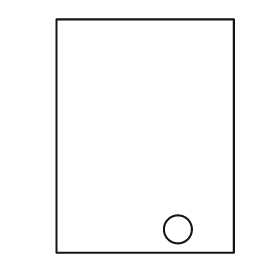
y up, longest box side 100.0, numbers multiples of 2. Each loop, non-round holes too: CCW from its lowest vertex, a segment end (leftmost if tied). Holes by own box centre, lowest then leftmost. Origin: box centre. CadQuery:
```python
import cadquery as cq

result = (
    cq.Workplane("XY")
    .moveTo(-38.0, -50.0)
    .lineTo(38.0, -50.0)
    .lineTo(38.0, 50.0)
    .lineTo(-38.0, 50.0)
    .close()
    .moveTo(14.0, -40.0)
    .circle(6.0)
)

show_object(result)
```